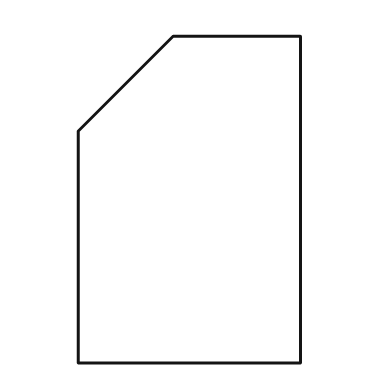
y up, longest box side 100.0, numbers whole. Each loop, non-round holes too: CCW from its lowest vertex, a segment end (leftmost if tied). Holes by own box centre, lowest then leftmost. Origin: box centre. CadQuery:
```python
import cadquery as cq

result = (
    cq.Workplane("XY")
    .moveTo(-34.0, -50.0)
    .lineTo(34.0, -50.0)
    .lineTo(34.0, 50.0)
    .lineTo(-5.0, 50.0)
    .lineTo(-34.0, 21.0)
    .close()
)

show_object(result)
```